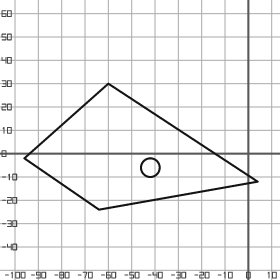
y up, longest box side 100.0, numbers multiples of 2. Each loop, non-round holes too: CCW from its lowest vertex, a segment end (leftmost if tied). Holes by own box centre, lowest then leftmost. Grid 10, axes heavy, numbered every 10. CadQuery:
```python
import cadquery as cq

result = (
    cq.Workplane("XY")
    .moveTo(-64.0, -24.0)
    .lineTo(4.0, -12.0)
    .lineTo(-60.0, 30.0)
    .lineTo(-96.0, -2.0)
    .close()
    .moveTo(-42.0, -6.0)
    .circle(4.0)
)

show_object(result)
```